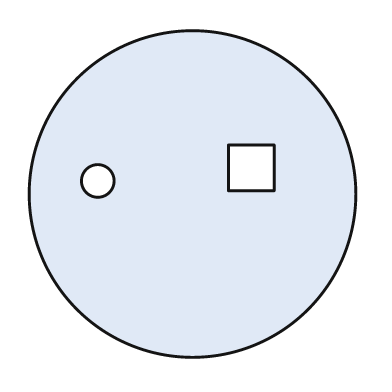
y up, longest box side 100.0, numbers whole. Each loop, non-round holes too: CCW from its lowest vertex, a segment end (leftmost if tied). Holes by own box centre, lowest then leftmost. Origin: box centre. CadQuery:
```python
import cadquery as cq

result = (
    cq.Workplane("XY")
    .moveTo(0.0, 0.0)
    .circle(50.0)
    .moveTo(-29.0, 4.0)
    .circle(5.0)
    .moveTo(11.0, 1.0)
    .lineTo(25.0, 1.0)
    .lineTo(25.0, 15.0)
    .lineTo(11.0, 15.0)
    .close()
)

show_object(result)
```